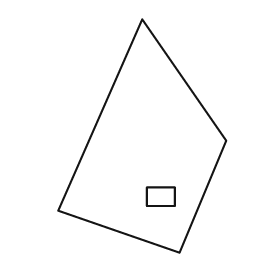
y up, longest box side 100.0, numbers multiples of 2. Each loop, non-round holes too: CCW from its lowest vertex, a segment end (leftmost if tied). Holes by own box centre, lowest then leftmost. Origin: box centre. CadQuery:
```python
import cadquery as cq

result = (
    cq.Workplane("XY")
    .moveTo(16.0, -50.0)
    .lineTo(36.0, -2.0)
    .lineTo(0.0, 50.0)
    .lineTo(-36.0, -32.0)
    .close()
    .moveTo(2.0, -30.0)
    .lineTo(14.0, -30.0)
    .lineTo(14.0, -22.0)
    .lineTo(2.0, -22.0)
    .close()
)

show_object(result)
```